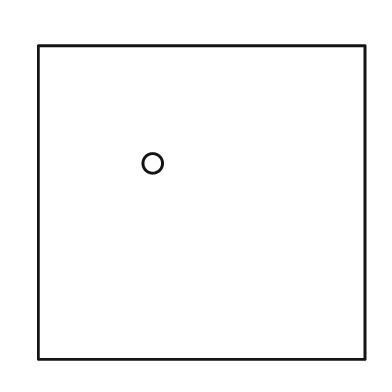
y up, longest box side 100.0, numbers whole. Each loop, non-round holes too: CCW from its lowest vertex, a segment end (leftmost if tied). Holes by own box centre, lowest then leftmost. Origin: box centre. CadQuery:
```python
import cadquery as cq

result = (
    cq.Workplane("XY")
    .moveTo(-50.0, -48.0)
    .lineTo(50.0, -48.0)
    .lineTo(50.0, 48.0)
    .lineTo(-50.0, 48.0)
    .close()
    .moveTo(-15.0, 12.0)
    .circle(3.0)
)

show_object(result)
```